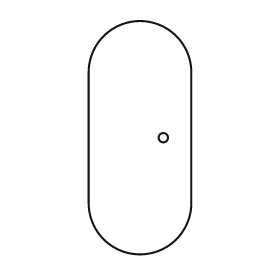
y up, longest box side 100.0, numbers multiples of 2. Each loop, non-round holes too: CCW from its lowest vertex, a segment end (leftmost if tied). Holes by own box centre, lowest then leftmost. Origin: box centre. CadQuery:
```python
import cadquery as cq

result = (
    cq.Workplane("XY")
    .moveTo(-22.0, -28.0)
    .threePointArc((0.0, -50.0), (22.0, -28.0))
    .lineTo(22.0, 28.0)
    .threePointArc((0.0, 50.0), (-22.0, 28.0))
    .close()
    .moveTo(10.0, 0.0)
    .circle(2.0)
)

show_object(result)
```